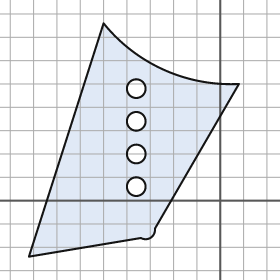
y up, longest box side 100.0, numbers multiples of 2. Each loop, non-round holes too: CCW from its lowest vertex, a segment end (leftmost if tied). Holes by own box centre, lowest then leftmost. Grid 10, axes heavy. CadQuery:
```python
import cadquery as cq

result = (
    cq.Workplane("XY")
    .moveTo(-82.0, -24.0)
    .lineTo(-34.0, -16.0)
    .threePointArc((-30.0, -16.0), (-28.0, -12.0))
    .lineTo(8.0, 50.0)
    .threePointArc((-24.0, 56.0), (-50.0, 76.0))
    .close()
    .moveTo(-36.0, 6.0)
    .circle(4.0)
    .moveTo(-36.0, 20.0)
    .circle(4.0)
    .moveTo(-36.0, 34.0)
    .circle(4.0)
    .moveTo(-36.0, 48.0)
    .circle(4.0)
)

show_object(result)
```